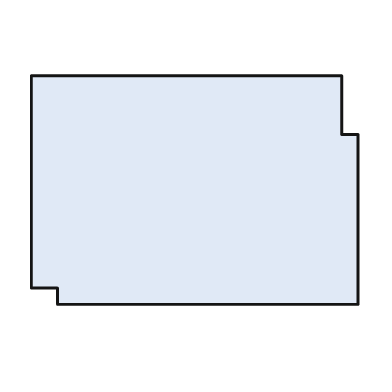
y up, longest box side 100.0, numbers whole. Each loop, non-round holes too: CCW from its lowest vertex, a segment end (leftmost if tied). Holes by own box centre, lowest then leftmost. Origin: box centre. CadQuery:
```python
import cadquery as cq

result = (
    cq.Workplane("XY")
    .moveTo(-42.0, -35.0)
    .lineTo(50.0, -35.0)
    .lineTo(50.0, 17.0)
    .lineTo(45.0, 17.0)
    .lineTo(45.0, 35.0)
    .lineTo(-50.0, 35.0)
    .lineTo(-50.0, -30.0)
    .lineTo(-42.0, -30.0)
    .close()
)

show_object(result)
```